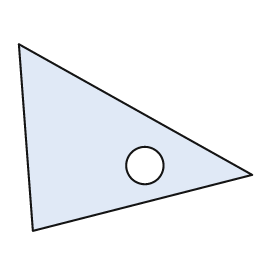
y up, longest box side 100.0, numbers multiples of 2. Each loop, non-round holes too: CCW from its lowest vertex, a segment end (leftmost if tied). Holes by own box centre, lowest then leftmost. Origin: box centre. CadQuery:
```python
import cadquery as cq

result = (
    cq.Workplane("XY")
    .moveTo(-44.0, -40.0)
    .lineTo(50.0, -16.0)
    .lineTo(-50.0, 40.0)
    .close()
    .moveTo(4.0, -12.0)
    .circle(8.0)
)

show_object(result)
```